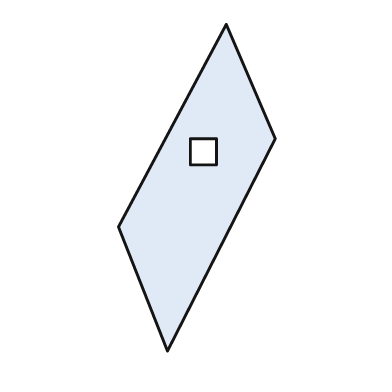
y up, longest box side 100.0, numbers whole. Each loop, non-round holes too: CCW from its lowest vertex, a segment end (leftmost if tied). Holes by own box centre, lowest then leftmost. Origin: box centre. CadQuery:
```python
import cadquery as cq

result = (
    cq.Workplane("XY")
    .moveTo(-9.0, -50.0)
    .lineTo(24.0, 15.0)
    .lineTo(9.0, 50.0)
    .lineTo(-24.0, -12.0)
    .close()
    .moveTo(-2.0, 7.0)
    .lineTo(6.0, 7.0)
    .lineTo(6.0, 15.0)
    .lineTo(-2.0, 15.0)
    .close()
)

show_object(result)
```